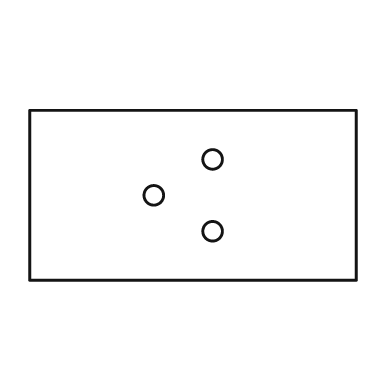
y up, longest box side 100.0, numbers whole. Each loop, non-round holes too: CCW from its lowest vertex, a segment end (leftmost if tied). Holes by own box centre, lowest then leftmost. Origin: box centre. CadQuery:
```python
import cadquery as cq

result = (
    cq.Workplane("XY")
    .moveTo(-50.0, -26.0)
    .lineTo(50.0, -26.0)
    .lineTo(50.0, 26.0)
    .lineTo(-50.0, 26.0)
    .close()
    .moveTo(6.0, -11.0)
    .circle(3.0)
    .moveTo(-12.0, 0.0)
    .circle(3.0)
    .moveTo(6.0, 11.0)
    .circle(3.0)
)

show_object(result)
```